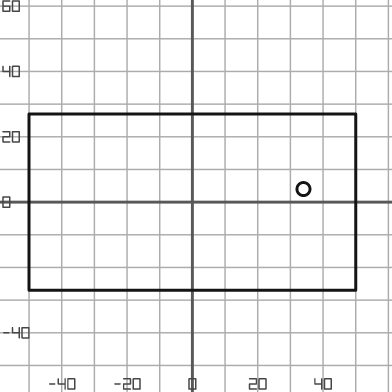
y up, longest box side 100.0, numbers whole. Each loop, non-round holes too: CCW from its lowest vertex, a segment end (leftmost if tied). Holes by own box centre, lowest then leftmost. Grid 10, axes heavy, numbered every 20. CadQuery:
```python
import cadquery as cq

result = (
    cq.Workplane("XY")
    .moveTo(-50.0, -27.0)
    .lineTo(50.0, -27.0)
    .lineTo(50.0, 27.0)
    .lineTo(-50.0, 27.0)
    .close()
    .moveTo(34.0, 4.0)
    .circle(2.0)
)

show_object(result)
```